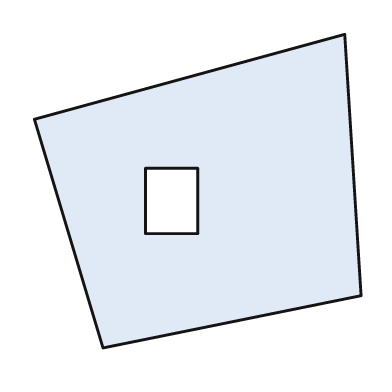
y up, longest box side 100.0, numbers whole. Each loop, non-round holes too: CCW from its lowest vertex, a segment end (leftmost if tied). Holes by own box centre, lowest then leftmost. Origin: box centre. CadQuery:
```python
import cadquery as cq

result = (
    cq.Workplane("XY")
    .moveTo(-29.0, -48.0)
    .lineTo(50.0, -32.0)
    .lineTo(45.0, 48.0)
    .lineTo(-50.0, 22.0)
    .close()
    .moveTo(-16.0, -13.0)
    .lineTo(0.0, -13.0)
    .lineTo(0.0, 7.0)
    .lineTo(-16.0, 7.0)
    .close()
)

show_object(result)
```